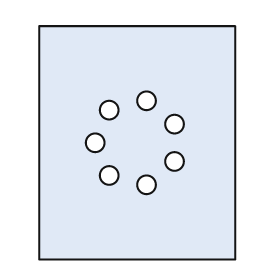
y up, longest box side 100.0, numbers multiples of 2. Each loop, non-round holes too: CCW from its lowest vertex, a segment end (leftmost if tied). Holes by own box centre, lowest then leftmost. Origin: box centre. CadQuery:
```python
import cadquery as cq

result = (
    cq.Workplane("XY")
    .moveTo(-42.0, -50.0)
    .lineTo(42.0, -50.0)
    .lineTo(42.0, 50.0)
    .lineTo(-42.0, 50.0)
    .close()
    .moveTo(4.0, -18.0)
    .circle(4.0)
    .moveTo(-12.0, -14.0)
    .circle(4.0)
    .moveTo(16.0, -8.0)
    .circle(4.0)
    .moveTo(-18.0, 0.0)
    .circle(4.0)
    .moveTo(16.0, 8.0)
    .circle(4.0)
    .moveTo(-12.0, 14.0)
    .circle(4.0)
    .moveTo(4.0, 18.0)
    .circle(4.0)
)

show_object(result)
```